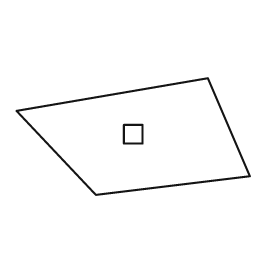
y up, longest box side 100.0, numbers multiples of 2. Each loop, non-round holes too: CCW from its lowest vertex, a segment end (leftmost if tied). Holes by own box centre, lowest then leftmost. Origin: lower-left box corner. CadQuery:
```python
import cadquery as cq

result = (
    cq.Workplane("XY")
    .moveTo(34.0, 0.0)
    .lineTo(100.0, 8.0)
    .lineTo(82.0, 50.0)
    .lineTo(0.0, 36.0)
    .close()
    .moveTo(46.0, 22.0)
    .lineTo(54.0, 22.0)
    .lineTo(54.0, 30.0)
    .lineTo(46.0, 30.0)
    .close()
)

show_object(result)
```